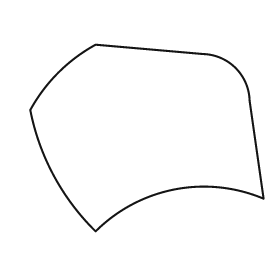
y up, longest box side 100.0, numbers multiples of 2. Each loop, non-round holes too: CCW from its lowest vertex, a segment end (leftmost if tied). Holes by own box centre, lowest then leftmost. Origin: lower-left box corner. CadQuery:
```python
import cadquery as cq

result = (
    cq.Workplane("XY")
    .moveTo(28.0, 0.0)
    .threePointArc((62.0, 18.0), (100.0, 14.0))
    .lineTo(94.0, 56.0)
    .threePointArc((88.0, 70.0), (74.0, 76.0))
    .lineTo(28.0, 80.0)
    .threePointArc((12.0, 68.0), (0.0, 52.0))
    .threePointArc((10.0, 24.0), (28.0, 0.0))
    .close()
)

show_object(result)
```